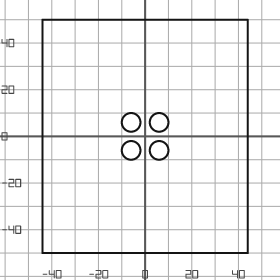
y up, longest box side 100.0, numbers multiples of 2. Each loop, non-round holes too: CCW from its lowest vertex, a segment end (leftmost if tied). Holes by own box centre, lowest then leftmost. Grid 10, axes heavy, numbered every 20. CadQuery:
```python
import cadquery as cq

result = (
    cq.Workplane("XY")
    .moveTo(-44.0, -50.0)
    .lineTo(44.0, -50.0)
    .lineTo(44.0, 50.0)
    .lineTo(-44.0, 50.0)
    .close()
    .moveTo(-6.0, -6.0)
    .circle(4.0)
    .moveTo(6.0, -6.0)
    .circle(4.0)
    .moveTo(-6.0, 6.0)
    .circle(4.0)
    .moveTo(6.0, 6.0)
    .circle(4.0)
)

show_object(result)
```